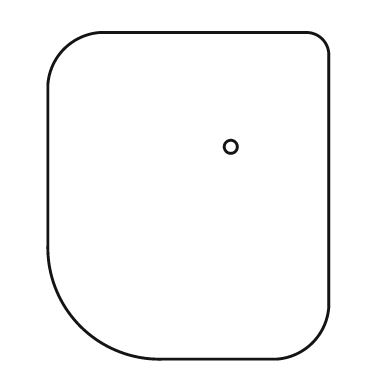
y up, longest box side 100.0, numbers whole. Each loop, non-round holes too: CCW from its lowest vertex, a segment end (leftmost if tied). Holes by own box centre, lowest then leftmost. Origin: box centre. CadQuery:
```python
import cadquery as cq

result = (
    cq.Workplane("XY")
    .moveTo(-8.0, -50.0)
    .lineTo(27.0, -50.0)
    .threePointArc((38.0, -45.0), (43.0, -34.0))
    .lineTo(43.0, 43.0)
    .threePointArc((41.0, 48.0), (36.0, 50.0))
    .lineTo(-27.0, 50.0)
    .threePointArc((-38.0, 45.0), (-43.0, 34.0))
    .lineTo(-43.0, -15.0)
    .threePointArc((-33.0, -40.0), (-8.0, -50.0))
    .close()
    .moveTo(13.0, 15.0)
    .circle(2.0)
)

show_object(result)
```